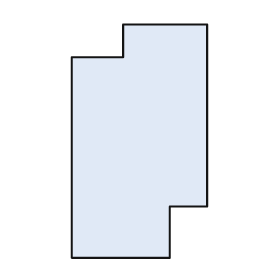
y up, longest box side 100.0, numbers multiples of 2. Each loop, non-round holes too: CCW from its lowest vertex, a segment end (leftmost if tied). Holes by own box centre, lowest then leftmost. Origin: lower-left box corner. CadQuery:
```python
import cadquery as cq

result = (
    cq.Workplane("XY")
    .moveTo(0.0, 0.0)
    .lineTo(42.0, 0.0)
    .lineTo(42.0, 22.0)
    .lineTo(58.0, 22.0)
    .lineTo(58.0, 100.0)
    .lineTo(22.0, 100.0)
    .lineTo(22.0, 86.0)
    .lineTo(0.0, 86.0)
    .close()
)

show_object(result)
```